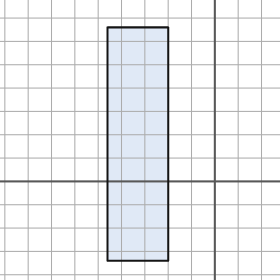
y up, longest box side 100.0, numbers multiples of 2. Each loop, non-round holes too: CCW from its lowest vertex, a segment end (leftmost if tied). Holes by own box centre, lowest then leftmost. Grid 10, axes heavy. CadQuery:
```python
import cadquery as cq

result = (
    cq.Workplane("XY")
    .moveTo(-46.0, -34.0)
    .lineTo(-20.0, -34.0)
    .lineTo(-20.0, 66.0)
    .lineTo(-46.0, 66.0)
    .close()
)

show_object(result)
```